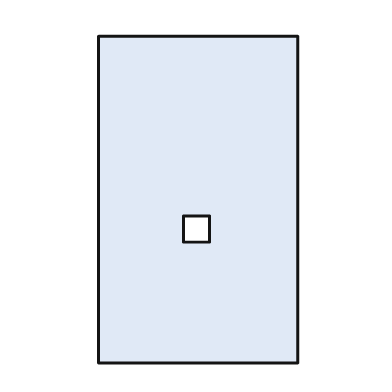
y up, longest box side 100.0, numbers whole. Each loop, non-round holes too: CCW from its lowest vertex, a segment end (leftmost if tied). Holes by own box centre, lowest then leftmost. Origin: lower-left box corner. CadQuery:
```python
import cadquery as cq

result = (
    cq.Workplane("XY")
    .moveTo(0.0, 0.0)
    .lineTo(61.0, 0.0)
    .lineTo(61.0, 100.0)
    .lineTo(0.0, 100.0)
    .close()
    .moveTo(26.0, 37.0)
    .lineTo(34.0, 37.0)
    .lineTo(34.0, 45.0)
    .lineTo(26.0, 45.0)
    .close()
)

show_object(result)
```